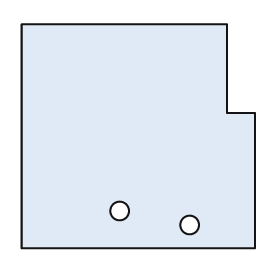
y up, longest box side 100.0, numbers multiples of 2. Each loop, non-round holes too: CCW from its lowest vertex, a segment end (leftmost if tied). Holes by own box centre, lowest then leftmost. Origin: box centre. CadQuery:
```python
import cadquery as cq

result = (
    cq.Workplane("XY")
    .moveTo(-50.0, -48.0)
    .lineTo(50.0, -48.0)
    .lineTo(50.0, 10.0)
    .lineTo(38.0, 10.0)
    .lineTo(38.0, 48.0)
    .lineTo(-50.0, 48.0)
    .close()
    .moveTo(22.0, -38.0)
    .circle(4.0)
    .moveTo(-8.0, -32.0)
    .circle(4.0)
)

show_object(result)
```